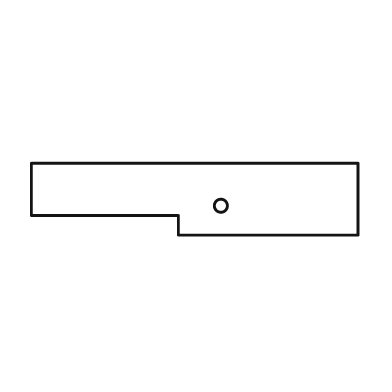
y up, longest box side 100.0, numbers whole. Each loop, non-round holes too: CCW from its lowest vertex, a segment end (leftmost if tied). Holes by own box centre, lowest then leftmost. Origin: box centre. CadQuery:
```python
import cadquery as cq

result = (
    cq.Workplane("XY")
    .moveTo(-5.0, -11.0)
    .lineTo(50.0, -11.0)
    .lineTo(50.0, 11.0)
    .lineTo(-50.0, 11.0)
    .lineTo(-50.0, -5.0)
    .lineTo(-5.0, -5.0)
    .close()
    .moveTo(8.0, -2.0)
    .circle(2.0)
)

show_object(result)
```